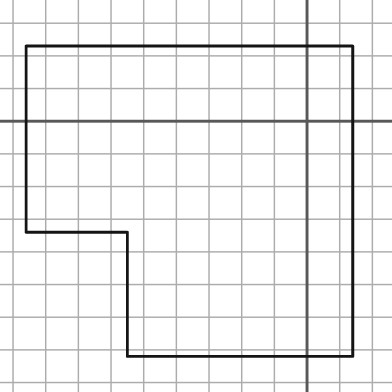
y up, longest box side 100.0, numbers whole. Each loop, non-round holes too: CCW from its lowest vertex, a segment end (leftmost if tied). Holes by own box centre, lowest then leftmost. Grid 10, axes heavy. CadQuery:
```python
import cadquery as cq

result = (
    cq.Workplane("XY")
    .moveTo(-55.0, -72.0)
    .lineTo(14.0, -72.0)
    .lineTo(14.0, 23.0)
    .lineTo(-86.0, 23.0)
    .lineTo(-86.0, -34.0)
    .lineTo(-55.0, -34.0)
    .close()
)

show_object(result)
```